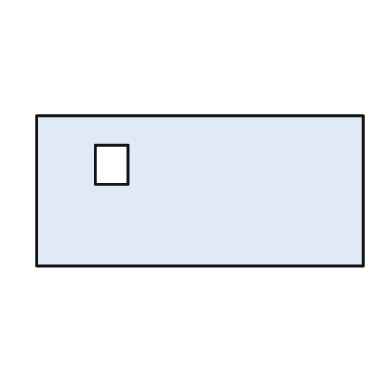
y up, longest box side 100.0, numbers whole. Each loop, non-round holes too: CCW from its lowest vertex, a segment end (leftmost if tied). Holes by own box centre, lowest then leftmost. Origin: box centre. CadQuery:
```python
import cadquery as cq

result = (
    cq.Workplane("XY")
    .moveTo(-50.0, -23.0)
    .lineTo(50.0, -23.0)
    .lineTo(50.0, 23.0)
    .lineTo(-50.0, 23.0)
    .close()
    .moveTo(-32.0, 2.0)
    .lineTo(-22.0, 2.0)
    .lineTo(-22.0, 14.0)
    .lineTo(-32.0, 14.0)
    .close()
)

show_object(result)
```